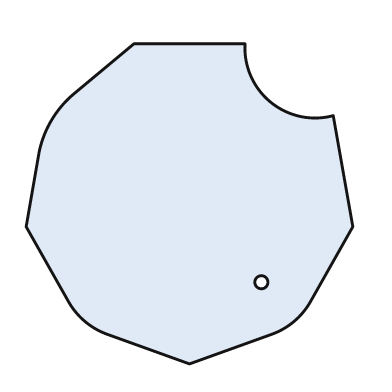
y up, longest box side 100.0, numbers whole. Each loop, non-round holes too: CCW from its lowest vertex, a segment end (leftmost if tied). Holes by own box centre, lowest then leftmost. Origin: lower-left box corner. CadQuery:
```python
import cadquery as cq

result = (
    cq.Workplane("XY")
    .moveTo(50.0, 0.0)
    .lineTo(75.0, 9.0)
    .threePointArc((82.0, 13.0), (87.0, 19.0))
    .lineTo(100.0, 42.0)
    .lineTo(94.0, 76.0)
    .threePointArc((75.0, 80.0), (67.0, 98.0))
    .lineTo(33.0, 98.0)
    .lineTo(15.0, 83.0)
    .threePointArc((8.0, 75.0), (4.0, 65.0))
    .lineTo(0.0, 42.0)
    .lineTo(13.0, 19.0)
    .threePointArc((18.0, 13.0), (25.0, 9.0))
    .close()
    .moveTo(72.0, 25.0)
    .circle(2.0)
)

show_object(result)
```